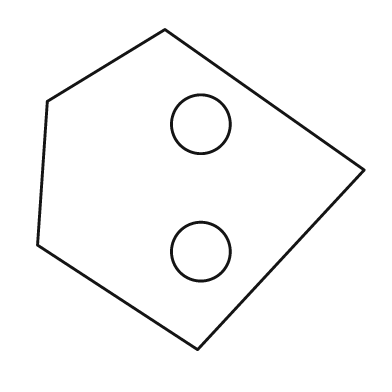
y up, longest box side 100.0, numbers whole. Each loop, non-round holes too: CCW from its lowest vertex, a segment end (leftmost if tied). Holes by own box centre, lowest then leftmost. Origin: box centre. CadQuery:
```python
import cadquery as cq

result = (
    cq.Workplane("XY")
    .moveTo(-1.0, -49.0)
    .lineTo(50.0, 6.0)
    .lineTo(-11.0, 49.0)
    .lineTo(-47.0, 27.0)
    .lineTo(-50.0, -17.0)
    .close()
    .moveTo(0.0, -19.0)
    .circle(9.0)
    .moveTo(0.0, 20.0)
    .circle(9.0)
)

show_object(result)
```